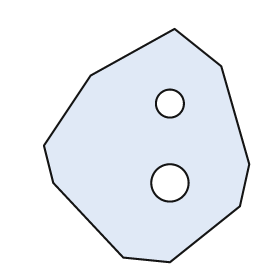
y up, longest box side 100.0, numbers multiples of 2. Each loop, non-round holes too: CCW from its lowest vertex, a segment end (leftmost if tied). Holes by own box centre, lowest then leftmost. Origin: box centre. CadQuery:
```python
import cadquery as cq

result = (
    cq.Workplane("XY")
    .moveTo(10.0, -50.0)
    .lineTo(40.0, -26.0)
    .lineTo(44.0, -8.0)
    .lineTo(32.0, 34.0)
    .lineTo(12.0, 50.0)
    .lineTo(-24.0, 30.0)
    .lineTo(-44.0, 0.0)
    .lineTo(-40.0, -16.0)
    .lineTo(-10.0, -48.0)
    .close()
    .moveTo(10.0, -16.0)
    .circle(8.0)
    .moveTo(10.0, 18.0)
    .circle(6.0)
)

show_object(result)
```